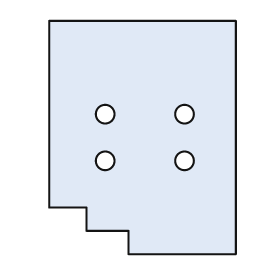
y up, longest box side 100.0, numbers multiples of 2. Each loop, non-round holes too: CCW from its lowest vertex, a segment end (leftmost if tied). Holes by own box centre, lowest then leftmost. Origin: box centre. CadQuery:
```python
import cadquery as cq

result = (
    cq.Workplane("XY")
    .moveTo(-6.0, -50.0)
    .lineTo(40.0, -50.0)
    .lineTo(40.0, 50.0)
    .lineTo(-40.0, 50.0)
    .lineTo(-40.0, -30.0)
    .lineTo(-24.0, -30.0)
    .lineTo(-24.0, -40.0)
    .lineTo(-6.0, -40.0)
    .close()
    .moveTo(-16.0, -10.0)
    .circle(4.0)
    .moveTo(18.0, -10.0)
    .circle(4.0)
    .moveTo(-16.0, 10.0)
    .circle(4.0)
    .moveTo(18.0, 10.0)
    .circle(4.0)
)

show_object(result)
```